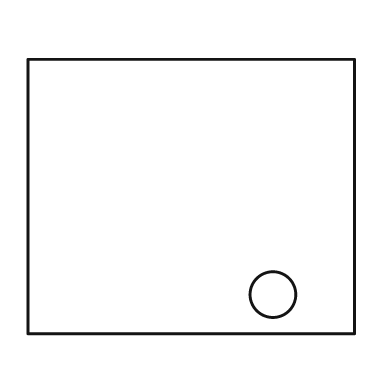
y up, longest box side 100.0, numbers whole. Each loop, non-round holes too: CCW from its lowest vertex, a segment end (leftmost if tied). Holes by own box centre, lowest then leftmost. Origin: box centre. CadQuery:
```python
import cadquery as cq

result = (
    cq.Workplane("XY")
    .moveTo(-50.0, -42.0)
    .lineTo(50.0, -42.0)
    .lineTo(50.0, 42.0)
    .lineTo(-50.0, 42.0)
    .close()
    .moveTo(25.0, -30.0)
    .circle(7.0)
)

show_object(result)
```